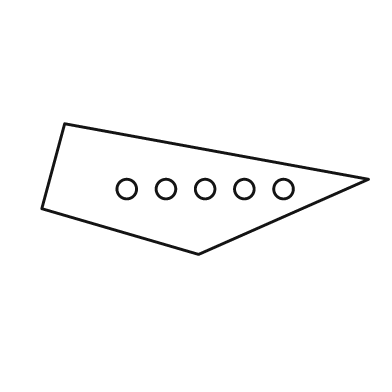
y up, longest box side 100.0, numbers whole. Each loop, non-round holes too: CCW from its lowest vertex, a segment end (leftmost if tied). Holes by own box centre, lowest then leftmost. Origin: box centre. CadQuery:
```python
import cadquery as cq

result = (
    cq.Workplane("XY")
    .moveTo(-2.0, -20.0)
    .lineTo(50.0, 3.0)
    .lineTo(-43.0, 20.0)
    .lineTo(-50.0, -6.0)
    .close()
    .moveTo(-24.0, 0.0)
    .circle(3.0)
    .moveTo(-12.0, 0.0)
    .circle(3.0)
    .moveTo(0.0, 0.0)
    .circle(3.0)
    .moveTo(12.0, 0.0)
    .circle(3.0)
    .moveTo(24.0, 0.0)
    .circle(3.0)
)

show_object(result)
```